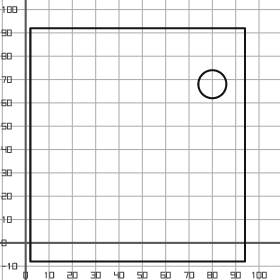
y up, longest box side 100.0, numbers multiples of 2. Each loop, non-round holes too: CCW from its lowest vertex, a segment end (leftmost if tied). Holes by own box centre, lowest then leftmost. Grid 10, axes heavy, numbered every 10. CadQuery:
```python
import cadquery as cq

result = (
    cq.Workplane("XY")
    .moveTo(2.0, -8.0)
    .lineTo(94.0, -8.0)
    .lineTo(94.0, 92.0)
    .lineTo(2.0, 92.0)
    .close()
    .moveTo(80.0, 68.0)
    .circle(6.0)
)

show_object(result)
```